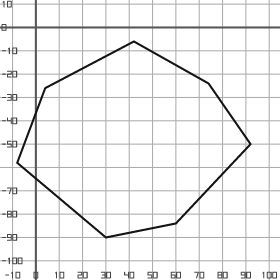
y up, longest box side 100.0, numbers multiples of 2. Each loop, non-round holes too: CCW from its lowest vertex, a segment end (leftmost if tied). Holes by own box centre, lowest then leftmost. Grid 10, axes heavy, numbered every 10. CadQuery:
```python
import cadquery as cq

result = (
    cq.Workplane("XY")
    .moveTo(30.0, -90.0)
    .lineTo(60.0, -84.0)
    .lineTo(92.0, -50.0)
    .lineTo(74.0, -24.0)
    .lineTo(42.0, -6.0)
    .lineTo(4.0, -26.0)
    .lineTo(-8.0, -58.0)
    .close()
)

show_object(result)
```